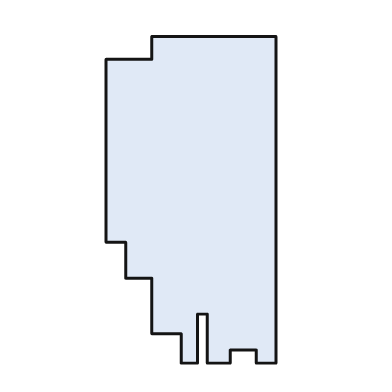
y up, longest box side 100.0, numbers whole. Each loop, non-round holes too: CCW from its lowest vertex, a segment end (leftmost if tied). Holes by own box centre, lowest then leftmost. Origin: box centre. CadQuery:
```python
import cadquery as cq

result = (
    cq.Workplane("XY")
    .moveTo(-3.0, -50.0)
    .lineTo(2.0, -50.0)
    .lineTo(2.0, -35.0)
    .lineTo(5.0, -35.0)
    .lineTo(5.0, -50.0)
    .lineTo(12.0, -50.0)
    .lineTo(12.0, -46.0)
    .lineTo(20.0, -46.0)
    .lineTo(20.0, -50.0)
    .lineTo(26.0, -50.0)
    .lineTo(26.0, 50.0)
    .lineTo(-12.0, 50.0)
    .lineTo(-12.0, 43.0)
    .lineTo(-26.0, 43.0)
    .lineTo(-26.0, -13.0)
    .lineTo(-20.0, -13.0)
    .lineTo(-20.0, -24.0)
    .lineTo(-12.0, -24.0)
    .lineTo(-12.0, -41.0)
    .lineTo(-3.0, -41.0)
    .close()
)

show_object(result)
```